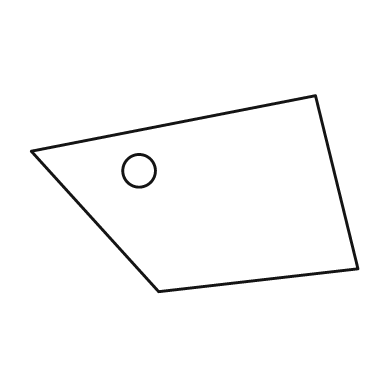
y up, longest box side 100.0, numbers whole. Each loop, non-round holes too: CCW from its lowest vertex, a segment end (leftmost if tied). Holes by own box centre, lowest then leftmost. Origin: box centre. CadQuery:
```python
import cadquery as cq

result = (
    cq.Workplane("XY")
    .moveTo(-11.0, -30.0)
    .lineTo(50.0, -23.0)
    .lineTo(37.0, 30.0)
    .lineTo(-50.0, 13.0)
    .close()
    .moveTo(-17.0, 7.0)
    .circle(5.0)
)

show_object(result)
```